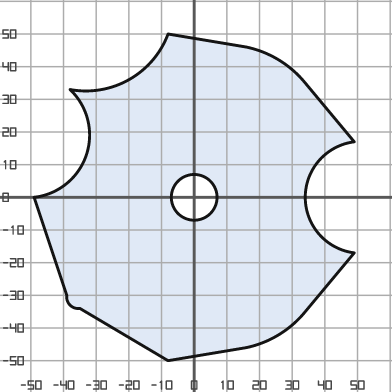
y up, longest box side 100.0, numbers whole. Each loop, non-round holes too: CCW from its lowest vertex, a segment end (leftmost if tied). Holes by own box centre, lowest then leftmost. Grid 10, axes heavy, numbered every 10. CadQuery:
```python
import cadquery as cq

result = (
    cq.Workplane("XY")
    .moveTo(-8.0, -50.0)
    .lineTo(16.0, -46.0)
    .threePointArc((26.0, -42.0), (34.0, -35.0))
    .lineTo(49.0, -17.0)
    .threePointArc((34.0, 0.0), (49.0, 17.0))
    .lineTo(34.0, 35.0)
    .threePointArc((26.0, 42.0), (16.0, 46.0))
    .lineTo(-8.0, 50.0)
    .threePointArc((-20.0, 36.0), (-38.0, 33.0))
    .threePointArc((-33.0, 13.0), (-49.0, 0.0))
    .lineTo(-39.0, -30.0)
    .threePointArc((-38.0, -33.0), (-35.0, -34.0))
    .close()
    .moveTo(0.0, 0.0)
    .circle(7.0)
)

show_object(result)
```